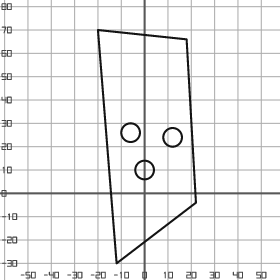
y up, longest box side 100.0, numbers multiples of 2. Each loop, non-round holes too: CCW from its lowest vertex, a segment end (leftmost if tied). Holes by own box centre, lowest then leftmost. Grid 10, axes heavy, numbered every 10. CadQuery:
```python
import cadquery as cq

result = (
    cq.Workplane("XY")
    .moveTo(-12.0, -30.0)
    .lineTo(22.0, -4.0)
    .lineTo(18.0, 66.0)
    .lineTo(-20.0, 70.0)
    .close()
    .moveTo(0.0, 10.0)
    .circle(4.0)
    .moveTo(12.0, 24.0)
    .circle(4.0)
    .moveTo(-6.0, 26.0)
    .circle(4.0)
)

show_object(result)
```